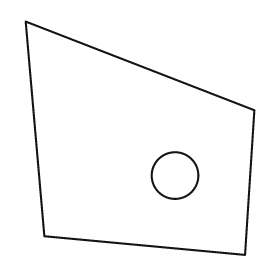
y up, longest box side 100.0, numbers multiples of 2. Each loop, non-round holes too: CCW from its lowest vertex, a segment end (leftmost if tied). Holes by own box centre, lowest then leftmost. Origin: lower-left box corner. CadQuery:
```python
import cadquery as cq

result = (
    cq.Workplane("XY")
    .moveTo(94.0, 0.0)
    .lineTo(98.0, 62.0)
    .lineTo(0.0, 100.0)
    .lineTo(8.0, 8.0)
    .close()
    .moveTo(64.0, 34.0)
    .circle(10.0)
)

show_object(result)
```